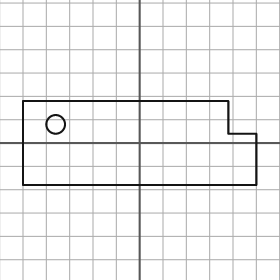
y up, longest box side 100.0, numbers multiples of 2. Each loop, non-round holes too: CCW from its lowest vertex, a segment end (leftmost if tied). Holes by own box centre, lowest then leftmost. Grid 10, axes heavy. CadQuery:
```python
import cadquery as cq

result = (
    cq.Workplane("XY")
    .moveTo(-50.0, -18.0)
    .lineTo(50.0, -18.0)
    .lineTo(50.0, 4.0)
    .lineTo(38.0, 4.0)
    .lineTo(38.0, 18.0)
    .lineTo(-50.0, 18.0)
    .close()
    .moveTo(-36.0, 8.0)
    .circle(4.0)
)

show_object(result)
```